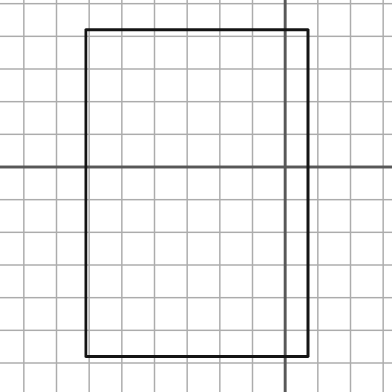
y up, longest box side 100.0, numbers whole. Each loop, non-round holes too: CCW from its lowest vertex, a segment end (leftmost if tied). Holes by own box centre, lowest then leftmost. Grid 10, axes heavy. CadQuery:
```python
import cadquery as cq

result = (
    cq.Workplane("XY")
    .moveTo(-61.0, -58.0)
    .lineTo(7.0, -58.0)
    .lineTo(7.0, 42.0)
    .lineTo(-61.0, 42.0)
    .close()
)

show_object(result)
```